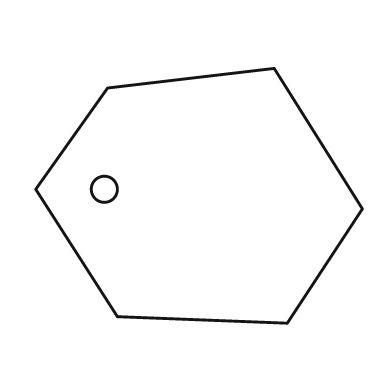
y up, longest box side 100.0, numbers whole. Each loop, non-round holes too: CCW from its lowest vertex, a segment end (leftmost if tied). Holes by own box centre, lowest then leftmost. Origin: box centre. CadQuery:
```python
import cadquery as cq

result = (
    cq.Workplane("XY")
    .moveTo(27.0, -39.0)
    .lineTo(50.0, -4.0)
    .lineTo(23.0, 39.0)
    .lineTo(-28.0, 33.0)
    .lineTo(-50.0, 2.0)
    .lineTo(-25.0, -37.0)
    .close()
    .moveTo(-29.0, 2.0)
    .circle(4.0)
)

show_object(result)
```